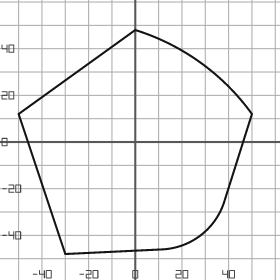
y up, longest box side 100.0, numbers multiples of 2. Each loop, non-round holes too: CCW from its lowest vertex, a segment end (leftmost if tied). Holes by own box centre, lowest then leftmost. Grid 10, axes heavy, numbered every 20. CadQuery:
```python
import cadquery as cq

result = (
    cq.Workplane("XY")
    .moveTo(-30.0, -48.0)
    .lineTo(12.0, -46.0)
    .threePointArc((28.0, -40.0), (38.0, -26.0))
    .lineTo(50.0, 12.0)
    .threePointArc((28.0, 34.0), (0.0, 48.0))
    .lineTo(-50.0, 12.0)
    .close()
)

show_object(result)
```